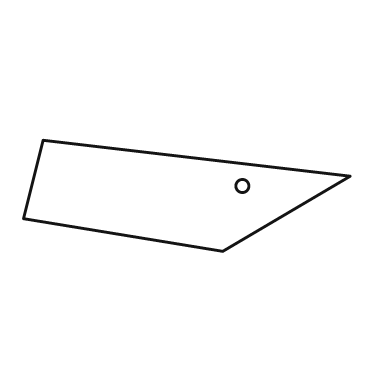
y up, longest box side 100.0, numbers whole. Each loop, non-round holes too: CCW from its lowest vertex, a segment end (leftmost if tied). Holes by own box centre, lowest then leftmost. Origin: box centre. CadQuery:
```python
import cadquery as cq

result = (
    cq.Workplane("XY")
    .moveTo(11.0, -17.0)
    .lineTo(50.0, 6.0)
    .lineTo(-44.0, 17.0)
    .lineTo(-50.0, -7.0)
    .close()
    .moveTo(17.0, 3.0)
    .circle(2.0)
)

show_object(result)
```